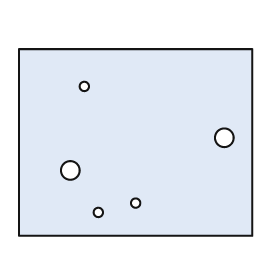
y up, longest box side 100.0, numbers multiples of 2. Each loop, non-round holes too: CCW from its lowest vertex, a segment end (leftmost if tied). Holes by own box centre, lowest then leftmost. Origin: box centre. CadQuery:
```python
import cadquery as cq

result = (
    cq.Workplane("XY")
    .moveTo(-50.0, -40.0)
    .lineTo(50.0, -40.0)
    .lineTo(50.0, 40.0)
    .lineTo(-50.0, 40.0)
    .close()
    .moveTo(-16.0, -30.0)
    .circle(2.0)
    .moveTo(0.0, -26.0)
    .circle(2.0)
    .moveTo(-28.0, -12.0)
    .circle(4.0)
    .moveTo(38.0, 2.0)
    .circle(4.0)
    .moveTo(-22.0, 24.0)
    .circle(2.0)
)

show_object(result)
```